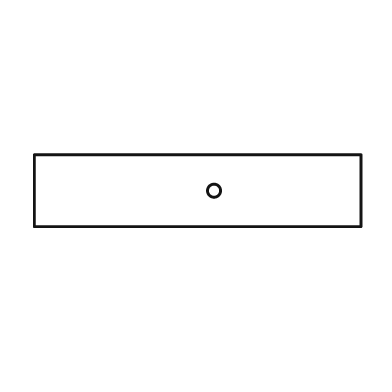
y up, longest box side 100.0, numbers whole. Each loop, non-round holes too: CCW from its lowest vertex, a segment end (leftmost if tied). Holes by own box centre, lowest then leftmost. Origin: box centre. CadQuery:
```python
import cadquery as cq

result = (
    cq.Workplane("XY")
    .moveTo(-50.0, -11.0)
    .lineTo(50.0, -11.0)
    .lineTo(50.0, 11.0)
    .lineTo(-50.0, 11.0)
    .close()
    .moveTo(5.0, 0.0)
    .circle(2.0)
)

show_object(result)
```